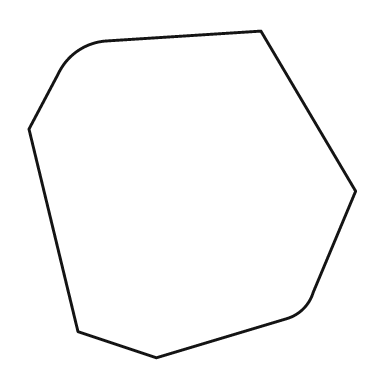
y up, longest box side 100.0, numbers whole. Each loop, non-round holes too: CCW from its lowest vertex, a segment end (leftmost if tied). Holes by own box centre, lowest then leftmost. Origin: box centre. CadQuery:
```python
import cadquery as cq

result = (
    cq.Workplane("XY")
    .moveTo(-11.0, -50.0)
    .lineTo(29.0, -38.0)
    .threePointArc((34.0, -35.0), (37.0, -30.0))
    .lineTo(50.0, 1.0)
    .lineTo(21.0, 50.0)
    .lineTo(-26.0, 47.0)
    .threePointArc((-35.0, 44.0), (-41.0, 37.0))
    .lineTo(-50.0, 20.0)
    .lineTo(-35.0, -42.0)
    .close()
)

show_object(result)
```